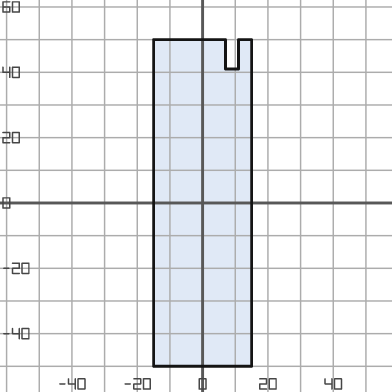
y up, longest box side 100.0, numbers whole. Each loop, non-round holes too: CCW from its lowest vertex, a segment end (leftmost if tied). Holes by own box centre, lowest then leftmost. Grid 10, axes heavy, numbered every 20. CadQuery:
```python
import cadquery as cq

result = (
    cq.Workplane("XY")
    .moveTo(-15.0, -50.0)
    .lineTo(15.0, -50.0)
    .lineTo(15.0, 50.0)
    .lineTo(11.0, 50.0)
    .lineTo(11.0, 41.0)
    .lineTo(7.0, 41.0)
    .lineTo(7.0, 50.0)
    .lineTo(-15.0, 50.0)
    .close()
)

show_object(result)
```